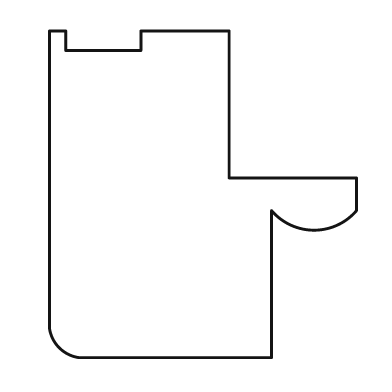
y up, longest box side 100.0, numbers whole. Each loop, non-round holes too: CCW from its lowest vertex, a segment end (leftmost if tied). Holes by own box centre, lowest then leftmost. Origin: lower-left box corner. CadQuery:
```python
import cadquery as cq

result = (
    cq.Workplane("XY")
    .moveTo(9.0, 0.0)
    .lineTo(68.0, 0.0)
    .lineTo(68.0, 45.0)
    .threePointArc((81.0, 39.0), (94.0, 45.0))
    .lineTo(94.0, 55.0)
    .lineTo(55.0, 55.0)
    .lineTo(55.0, 100.0)
    .lineTo(28.0, 100.0)
    .lineTo(28.0, 94.0)
    .lineTo(5.0, 94.0)
    .lineTo(5.0, 100.0)
    .lineTo(0.0, 100.0)
    .lineTo(0.0, 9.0)
    .threePointArc((3.0, 3.0), (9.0, 0.0))
    .close()
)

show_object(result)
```